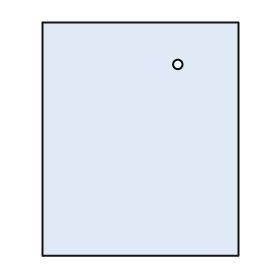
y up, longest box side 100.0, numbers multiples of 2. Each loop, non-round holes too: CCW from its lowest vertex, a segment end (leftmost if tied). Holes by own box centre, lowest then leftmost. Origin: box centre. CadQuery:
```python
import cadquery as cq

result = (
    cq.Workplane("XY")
    .moveTo(-42.0, -50.0)
    .lineTo(42.0, -50.0)
    .lineTo(42.0, 50.0)
    .lineTo(-42.0, 50.0)
    .close()
    .moveTo(16.0, 32.0)
    .circle(2.0)
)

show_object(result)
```